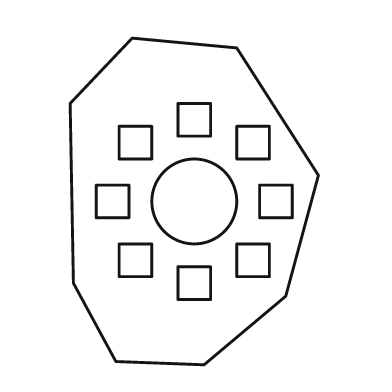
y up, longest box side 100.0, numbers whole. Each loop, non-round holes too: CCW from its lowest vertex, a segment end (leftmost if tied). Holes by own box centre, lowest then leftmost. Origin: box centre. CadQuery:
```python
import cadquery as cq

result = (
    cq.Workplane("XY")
    .moveTo(3.0, -50.0)
    .lineTo(28.0, -29.0)
    .lineTo(38.0, 8.0)
    .lineTo(13.0, 47.0)
    .lineTo(-19.0, 50.0)
    .lineTo(-38.0, 30.0)
    .lineTo(-37.0, -25.0)
    .lineTo(-24.0, -49.0)
    .close()
    .moveTo(-5.0, -30.0)
    .lineTo(5.0, -30.0)
    .lineTo(5.0, -20.0)
    .lineTo(-5.0, -20.0)
    .close()
    .moveTo(-23.0, -23.0)
    .lineTo(-13.0, -23.0)
    .lineTo(-13.0, -13.0)
    .lineTo(-23.0, -13.0)
    .close()
    .moveTo(13.0, -23.0)
    .lineTo(23.0, -23.0)
    .lineTo(23.0, -13.0)
    .lineTo(13.0, -13.0)
    .close()
    .moveTo(-30.0, -5.0)
    .lineTo(-20.0, -5.0)
    .lineTo(-20.0, 5.0)
    .lineTo(-30.0, 5.0)
    .close()
    .moveTo(0.0, 0.0)
    .circle(13.0)
    .moveTo(20.0, -5.0)
    .lineTo(30.0, -5.0)
    .lineTo(30.0, 5.0)
    .lineTo(20.0, 5.0)
    .close()
    .moveTo(-23.0, 13.0)
    .lineTo(-13.0, 13.0)
    .lineTo(-13.0, 23.0)
    .lineTo(-23.0, 23.0)
    .close()
    .moveTo(13.0, 13.0)
    .lineTo(23.0, 13.0)
    .lineTo(23.0, 23.0)
    .lineTo(13.0, 23.0)
    .close()
    .moveTo(-5.0, 20.0)
    .lineTo(5.0, 20.0)
    .lineTo(5.0, 30.0)
    .lineTo(-5.0, 30.0)
    .close()
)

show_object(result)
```